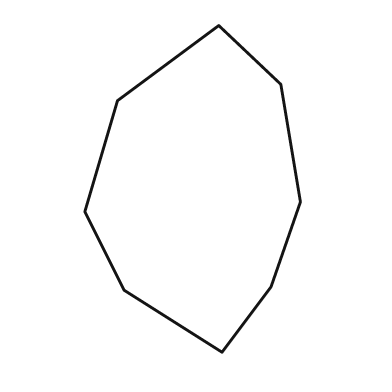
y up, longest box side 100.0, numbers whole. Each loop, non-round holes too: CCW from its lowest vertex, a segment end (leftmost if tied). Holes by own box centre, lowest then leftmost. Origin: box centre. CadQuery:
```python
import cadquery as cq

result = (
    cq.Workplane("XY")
    .moveTo(9.0, -50.0)
    .lineTo(24.0, -30.0)
    .lineTo(33.0, -4.0)
    .lineTo(27.0, 32.0)
    .lineTo(8.0, 50.0)
    .lineTo(-23.0, 27.0)
    .lineTo(-33.0, -7.0)
    .lineTo(-21.0, -31.0)
    .close()
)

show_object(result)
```